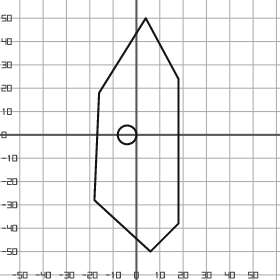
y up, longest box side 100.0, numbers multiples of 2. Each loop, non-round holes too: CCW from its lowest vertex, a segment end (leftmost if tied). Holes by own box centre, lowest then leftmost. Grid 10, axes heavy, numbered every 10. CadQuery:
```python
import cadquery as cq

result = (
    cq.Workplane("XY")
    .moveTo(6.0, -50.0)
    .lineTo(18.0, -38.0)
    .lineTo(18.0, 24.0)
    .lineTo(4.0, 50.0)
    .lineTo(-16.0, 18.0)
    .lineTo(-18.0, -28.0)
    .close()
    .moveTo(-4.0, 0.0)
    .circle(4.0)
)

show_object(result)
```